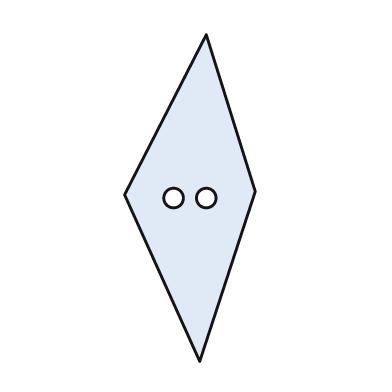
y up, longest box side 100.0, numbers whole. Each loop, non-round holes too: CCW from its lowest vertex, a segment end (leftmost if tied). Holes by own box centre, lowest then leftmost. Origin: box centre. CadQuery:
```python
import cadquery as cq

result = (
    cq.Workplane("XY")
    .moveTo(3.0, -50.0)
    .lineTo(20.0, 2.0)
    .lineTo(5.0, 50.0)
    .lineTo(-20.0, 1.0)
    .close()
    .moveTo(-5.0, 0.0)
    .circle(3.0)
    .moveTo(5.0, 0.0)
    .circle(3.0)
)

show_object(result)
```